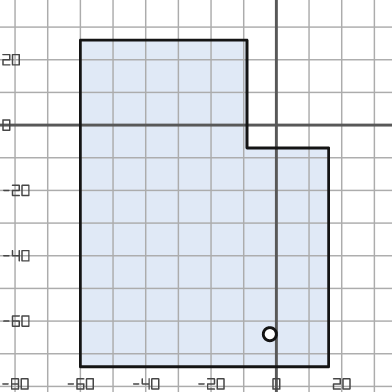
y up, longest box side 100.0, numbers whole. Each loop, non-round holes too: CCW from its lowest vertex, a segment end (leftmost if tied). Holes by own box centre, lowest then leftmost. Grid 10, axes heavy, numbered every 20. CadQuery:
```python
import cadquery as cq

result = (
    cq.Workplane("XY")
    .moveTo(-60.0, -74.0)
    .lineTo(16.0, -74.0)
    .lineTo(16.0, -7.0)
    .lineTo(-9.0, -7.0)
    .lineTo(-9.0, 26.0)
    .lineTo(-60.0, 26.0)
    .close()
    .moveTo(-2.0, -64.0)
    .circle(2.0)
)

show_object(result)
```